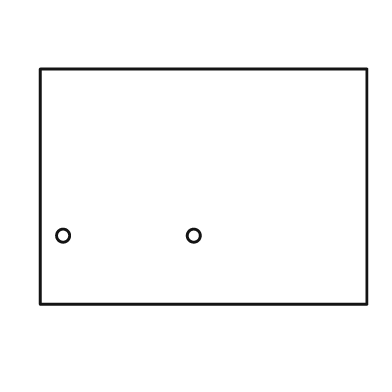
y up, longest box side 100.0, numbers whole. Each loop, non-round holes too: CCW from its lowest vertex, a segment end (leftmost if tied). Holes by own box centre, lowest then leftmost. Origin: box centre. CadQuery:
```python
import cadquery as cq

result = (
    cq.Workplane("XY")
    .moveTo(-50.0, -36.0)
    .lineTo(50.0, -36.0)
    .lineTo(50.0, 36.0)
    .lineTo(-50.0, 36.0)
    .close()
    .moveTo(-43.0, -15.0)
    .circle(2.0)
    .moveTo(-3.0, -15.0)
    .circle(2.0)
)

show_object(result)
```